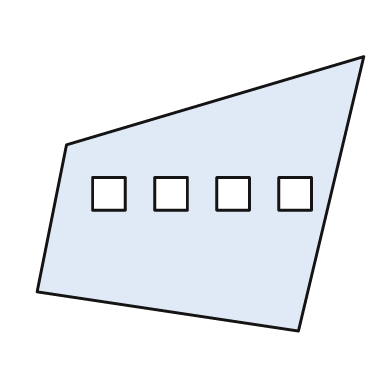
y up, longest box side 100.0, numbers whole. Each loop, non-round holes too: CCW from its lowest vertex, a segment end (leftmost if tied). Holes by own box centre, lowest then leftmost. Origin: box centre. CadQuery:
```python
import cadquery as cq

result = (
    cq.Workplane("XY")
    .moveTo(30.0, -42.0)
    .lineTo(50.0, 42.0)
    .lineTo(-41.0, 15.0)
    .lineTo(-50.0, -30.0)
    .close()
    .moveTo(-33.0, -5.0)
    .lineTo(-23.0, -5.0)
    .lineTo(-23.0, 5.0)
    .lineTo(-33.0, 5.0)
    .close()
    .moveTo(-14.0, -5.0)
    .lineTo(-4.0, -5.0)
    .lineTo(-4.0, 5.0)
    .lineTo(-14.0, 5.0)
    .close()
    .moveTo(5.0, -5.0)
    .lineTo(15.0, -5.0)
    .lineTo(15.0, 5.0)
    .lineTo(5.0, 5.0)
    .close()
    .moveTo(24.0, -5.0)
    .lineTo(34.0, -5.0)
    .lineTo(34.0, 5.0)
    .lineTo(24.0, 5.0)
    .close()
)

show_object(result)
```